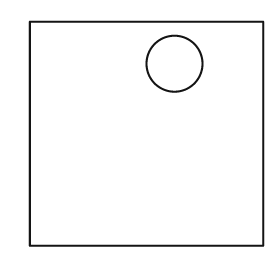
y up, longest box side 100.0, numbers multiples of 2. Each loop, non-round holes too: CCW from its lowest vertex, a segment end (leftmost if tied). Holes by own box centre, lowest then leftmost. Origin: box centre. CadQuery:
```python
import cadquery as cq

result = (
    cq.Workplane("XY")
    .moveTo(-50.0, -48.0)
    .lineTo(50.0, -48.0)
    .lineTo(50.0, 48.0)
    .lineTo(-50.0, 48.0)
    .close()
    .moveTo(12.0, 30.0)
    .circle(12.0)
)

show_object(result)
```